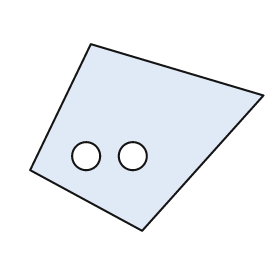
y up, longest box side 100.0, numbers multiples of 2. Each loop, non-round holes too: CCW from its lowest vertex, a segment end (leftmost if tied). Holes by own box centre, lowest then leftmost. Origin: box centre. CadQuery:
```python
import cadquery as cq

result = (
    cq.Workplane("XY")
    .moveTo(-2.0, -40.0)
    .lineTo(50.0, 18.0)
    .lineTo(-24.0, 40.0)
    .lineTo(-50.0, -14.0)
    .close()
    .moveTo(-26.0, -8.0)
    .circle(6.0)
    .moveTo(-6.0, -8.0)
    .circle(6.0)
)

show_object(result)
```